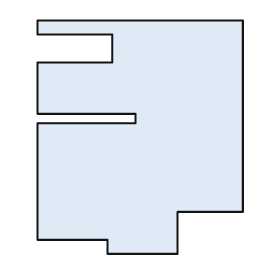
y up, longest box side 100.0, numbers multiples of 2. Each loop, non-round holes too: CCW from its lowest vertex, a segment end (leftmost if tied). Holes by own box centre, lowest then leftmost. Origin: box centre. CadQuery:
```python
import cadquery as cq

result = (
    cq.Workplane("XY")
    .moveTo(-14.0, -50.0)
    .lineTo(16.0, -50.0)
    .lineTo(16.0, -32.0)
    .lineTo(44.0, -32.0)
    .lineTo(44.0, 50.0)
    .lineTo(-44.0, 50.0)
    .lineTo(-44.0, 44.0)
    .lineTo(-12.0, 44.0)
    .lineTo(-12.0, 32.0)
    .lineTo(-44.0, 32.0)
    .lineTo(-44.0, 10.0)
    .lineTo(-2.0, 10.0)
    .lineTo(-2.0, 6.0)
    .lineTo(-44.0, 6.0)
    .lineTo(-44.0, -44.0)
    .lineTo(-14.0, -44.0)
    .close()
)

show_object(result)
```